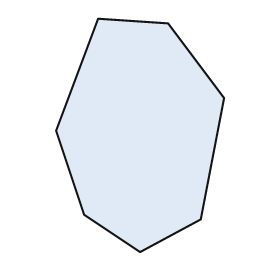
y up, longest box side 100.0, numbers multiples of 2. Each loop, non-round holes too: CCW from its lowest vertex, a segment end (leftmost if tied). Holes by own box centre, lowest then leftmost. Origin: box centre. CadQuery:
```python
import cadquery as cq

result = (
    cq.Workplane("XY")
    .moveTo(0.0, -50.0)
    .lineTo(26.0, -36.0)
    .lineTo(36.0, 16.0)
    .lineTo(12.0, 48.0)
    .lineTo(-18.0, 50.0)
    .lineTo(-36.0, 2.0)
    .lineTo(-24.0, -34.0)
    .close()
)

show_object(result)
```